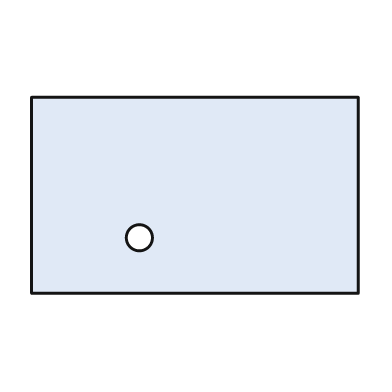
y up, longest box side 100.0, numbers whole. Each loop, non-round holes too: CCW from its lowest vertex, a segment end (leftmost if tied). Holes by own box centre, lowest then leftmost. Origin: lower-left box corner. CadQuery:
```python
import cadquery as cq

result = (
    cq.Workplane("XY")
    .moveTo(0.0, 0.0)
    .lineTo(100.0, 0.0)
    .lineTo(100.0, 60.0)
    .lineTo(0.0, 60.0)
    .close()
    .moveTo(33.0, 17.0)
    .circle(4.0)
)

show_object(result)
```